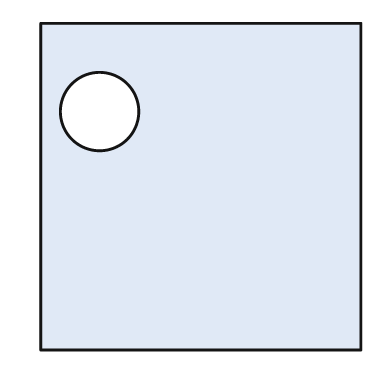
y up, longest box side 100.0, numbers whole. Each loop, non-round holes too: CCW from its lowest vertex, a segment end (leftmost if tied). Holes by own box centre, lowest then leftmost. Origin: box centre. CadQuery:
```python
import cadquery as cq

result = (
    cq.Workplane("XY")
    .moveTo(-49.0, -50.0)
    .lineTo(49.0, -50.0)
    .lineTo(49.0, 50.0)
    .lineTo(-49.0, 50.0)
    .close()
    .moveTo(-31.0, 23.0)
    .circle(12.0)
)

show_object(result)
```